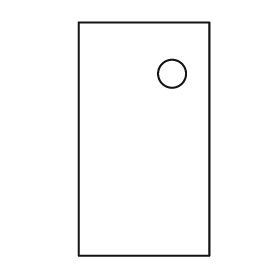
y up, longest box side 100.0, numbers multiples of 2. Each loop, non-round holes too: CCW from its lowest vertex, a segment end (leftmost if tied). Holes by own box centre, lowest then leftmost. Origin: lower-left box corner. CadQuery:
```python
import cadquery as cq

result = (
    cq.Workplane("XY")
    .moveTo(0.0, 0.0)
    .lineTo(56.0, 0.0)
    .lineTo(56.0, 100.0)
    .lineTo(0.0, 100.0)
    .close()
    .moveTo(40.0, 78.0)
    .circle(6.0)
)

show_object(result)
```